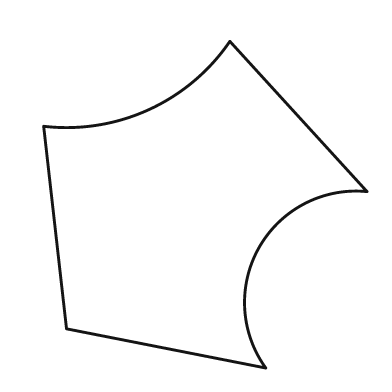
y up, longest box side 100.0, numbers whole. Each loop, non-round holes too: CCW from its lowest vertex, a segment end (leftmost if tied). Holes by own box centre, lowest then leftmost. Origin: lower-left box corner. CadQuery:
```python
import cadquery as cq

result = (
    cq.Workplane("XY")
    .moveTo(68.0, 0.0)
    .threePointArc((66.0, 37.0), (99.0, 54.0))
    .lineTo(57.0, 100.0)
    .threePointArc((32.0, 79.0), (0.0, 74.0))
    .lineTo(7.0, 12.0)
    .close()
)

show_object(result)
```